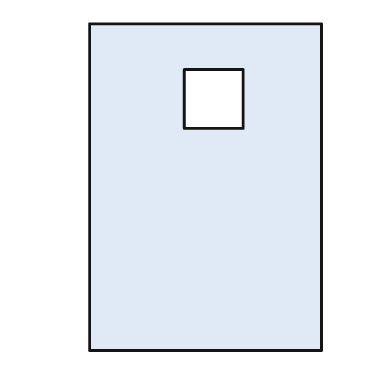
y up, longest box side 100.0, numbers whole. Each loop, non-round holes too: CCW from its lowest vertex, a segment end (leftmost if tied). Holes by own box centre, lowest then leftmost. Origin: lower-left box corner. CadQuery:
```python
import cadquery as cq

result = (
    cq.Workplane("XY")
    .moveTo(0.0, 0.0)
    .lineTo(71.0, 0.0)
    .lineTo(71.0, 100.0)
    .lineTo(0.0, 100.0)
    .close()
    .moveTo(29.0, 68.0)
    .lineTo(47.0, 68.0)
    .lineTo(47.0, 86.0)
    .lineTo(29.0, 86.0)
    .close()
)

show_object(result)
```